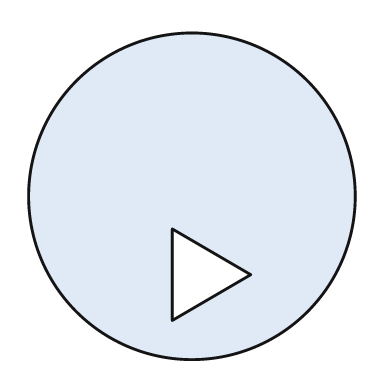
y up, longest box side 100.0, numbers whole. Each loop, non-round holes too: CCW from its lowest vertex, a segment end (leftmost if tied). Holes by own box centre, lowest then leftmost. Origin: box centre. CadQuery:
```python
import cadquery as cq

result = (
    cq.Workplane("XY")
    .moveTo(0.0, 0.0)
    .circle(50.0)
    .moveTo(-6.0, -38.0)
    .lineTo(18.0, -24.0)
    .lineTo(-6.0, -10.0)
    .close()
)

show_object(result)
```